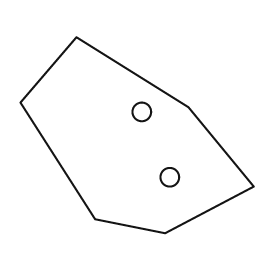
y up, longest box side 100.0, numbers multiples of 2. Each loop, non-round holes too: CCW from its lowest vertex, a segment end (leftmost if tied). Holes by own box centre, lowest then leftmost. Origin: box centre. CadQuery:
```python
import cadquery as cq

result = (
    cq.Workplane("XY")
    .moveTo(12.0, -42.0)
    .lineTo(50.0, -22.0)
    .lineTo(22.0, 12.0)
    .lineTo(-26.0, 42.0)
    .lineTo(-50.0, 14.0)
    .lineTo(-18.0, -36.0)
    .close()
    .moveTo(14.0, -18.0)
    .circle(4.0)
    .moveTo(2.0, 10.0)
    .circle(4.0)
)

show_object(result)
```